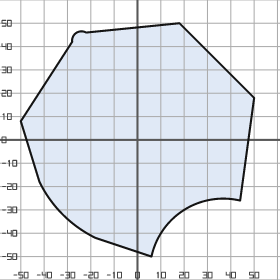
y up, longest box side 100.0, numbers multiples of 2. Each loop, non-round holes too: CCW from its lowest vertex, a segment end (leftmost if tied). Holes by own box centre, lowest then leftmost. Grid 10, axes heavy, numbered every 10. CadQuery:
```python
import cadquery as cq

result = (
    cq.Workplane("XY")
    .moveTo(6.0, -50.0)
    .threePointArc((20.0, -30.0), (44.0, -26.0))
    .lineTo(50.0, 18.0)
    .lineTo(18.0, 50.0)
    .lineTo(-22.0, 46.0)
    .threePointArc((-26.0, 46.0), (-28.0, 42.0))
    .lineTo(-50.0, 8.0)
    .lineTo(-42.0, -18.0)
    .threePointArc((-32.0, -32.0), (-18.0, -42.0))
    .close()
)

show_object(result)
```